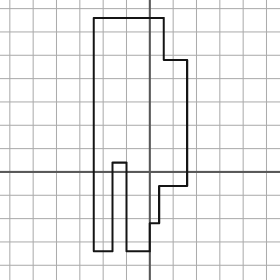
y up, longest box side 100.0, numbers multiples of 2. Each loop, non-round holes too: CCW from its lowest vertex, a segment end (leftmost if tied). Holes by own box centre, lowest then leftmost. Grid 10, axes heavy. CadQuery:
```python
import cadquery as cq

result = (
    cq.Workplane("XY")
    .moveTo(-24.0, -34.0)
    .lineTo(-16.0, -34.0)
    .lineTo(-16.0, 4.0)
    .lineTo(-10.0, 4.0)
    .lineTo(-10.0, -34.0)
    .lineTo(0.0, -34.0)
    .lineTo(0.0, -22.0)
    .lineTo(4.0, -22.0)
    .lineTo(4.0, -6.0)
    .lineTo(16.0, -6.0)
    .lineTo(16.0, 48.0)
    .lineTo(6.0, 48.0)
    .lineTo(6.0, 66.0)
    .lineTo(-24.0, 66.0)
    .close()
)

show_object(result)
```